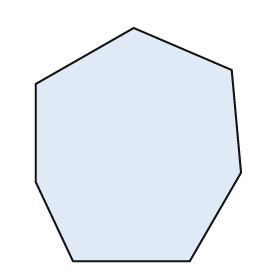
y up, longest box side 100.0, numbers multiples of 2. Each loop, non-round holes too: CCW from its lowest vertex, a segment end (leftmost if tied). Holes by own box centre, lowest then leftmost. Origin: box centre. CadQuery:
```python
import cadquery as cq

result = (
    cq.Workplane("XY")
    .moveTo(-28.0, -50.0)
    .lineTo(22.0, -50.0)
    .lineTo(44.0, -12.0)
    .lineTo(40.0, 32.0)
    .lineTo(-2.0, 50.0)
    .lineTo(-44.0, 26.0)
    .lineTo(-44.0, -16.0)
    .close()
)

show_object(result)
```